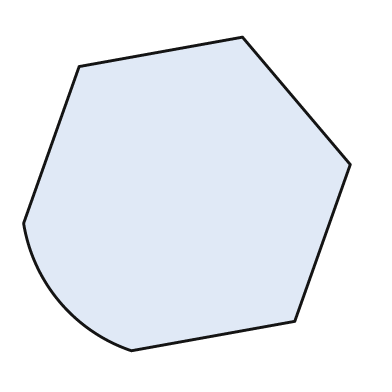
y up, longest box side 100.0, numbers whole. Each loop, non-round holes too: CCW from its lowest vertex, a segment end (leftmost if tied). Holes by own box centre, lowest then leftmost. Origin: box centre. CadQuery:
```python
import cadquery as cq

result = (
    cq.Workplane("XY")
    .moveTo(-17.0, -48.0)
    .lineTo(33.0, -39.0)
    .lineTo(50.0, 9.0)
    .lineTo(17.0, 48.0)
    .lineTo(-33.0, 39.0)
    .lineTo(-50.0, -9.0)
    .threePointArc((-39.0, -33.0), (-17.0, -48.0))
    .close()
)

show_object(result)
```